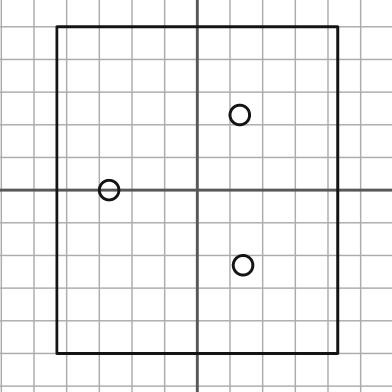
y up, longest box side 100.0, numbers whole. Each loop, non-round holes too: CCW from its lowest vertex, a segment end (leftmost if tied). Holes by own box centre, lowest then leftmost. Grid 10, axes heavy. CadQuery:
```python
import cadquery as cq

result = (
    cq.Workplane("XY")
    .moveTo(-43.0, -50.0)
    .lineTo(43.0, -50.0)
    .lineTo(43.0, 50.0)
    .lineTo(-43.0, 50.0)
    .close()
    .moveTo(14.0, -23.0)
    .circle(3.0)
    .moveTo(-27.0, 0.0)
    .circle(3.0)
    .moveTo(13.0, 23.0)
    .circle(3.0)
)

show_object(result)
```